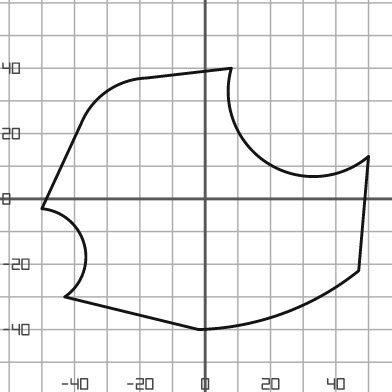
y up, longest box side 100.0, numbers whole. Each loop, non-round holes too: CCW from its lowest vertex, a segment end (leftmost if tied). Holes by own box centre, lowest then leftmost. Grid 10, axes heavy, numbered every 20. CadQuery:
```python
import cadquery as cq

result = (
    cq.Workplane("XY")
    .moveTo(-2.0, -40.0)
    .threePointArc((24.0, -35.0), (47.0, -22.0))
    .lineTo(50.0, 13.0)
    .threePointArc((19.0, 11.0), (8.0, 40.0))
    .lineTo(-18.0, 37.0)
    .threePointArc((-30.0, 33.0), (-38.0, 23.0))
    .lineTo(-50.0, -3.0)
    .threePointArc((-37.0, -14.0), (-43.0, -30.0))
    .close()
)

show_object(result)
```